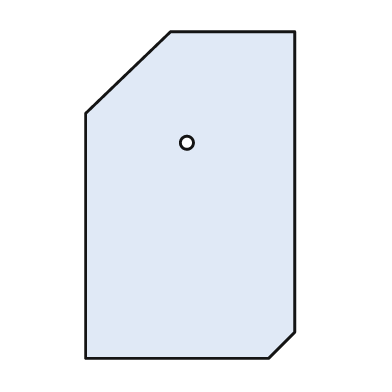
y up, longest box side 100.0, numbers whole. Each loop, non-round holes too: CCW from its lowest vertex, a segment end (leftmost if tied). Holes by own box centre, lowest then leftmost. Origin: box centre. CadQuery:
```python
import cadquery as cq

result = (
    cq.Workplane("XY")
    .moveTo(-32.0, -50.0)
    .lineTo(24.0, -50.0)
    .lineTo(32.0, -42.0)
    .lineTo(32.0, 50.0)
    .lineTo(-6.0, 50.0)
    .lineTo(-32.0, 25.0)
    .close()
    .moveTo(-1.0, 16.0)
    .circle(2.0)
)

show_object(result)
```